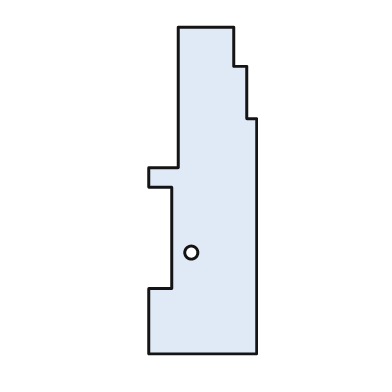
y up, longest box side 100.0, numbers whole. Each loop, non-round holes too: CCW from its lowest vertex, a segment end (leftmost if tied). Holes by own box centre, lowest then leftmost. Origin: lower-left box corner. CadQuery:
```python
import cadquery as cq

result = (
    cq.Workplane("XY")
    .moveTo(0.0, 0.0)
    .lineTo(33.0, 0.0)
    .lineTo(33.0, 72.0)
    .lineTo(30.0, 72.0)
    .lineTo(30.0, 88.0)
    .lineTo(26.0, 88.0)
    .lineTo(26.0, 100.0)
    .lineTo(9.0, 100.0)
    .lineTo(9.0, 57.0)
    .lineTo(0.0, 57.0)
    .lineTo(0.0, 51.0)
    .lineTo(7.0, 51.0)
    .lineTo(7.0, 20.0)
    .lineTo(0.0, 20.0)
    .close()
    .moveTo(13.0, 31.0)
    .circle(2.0)
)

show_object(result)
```